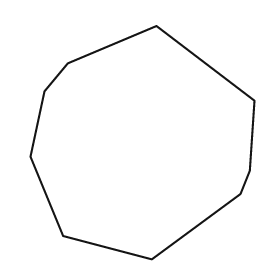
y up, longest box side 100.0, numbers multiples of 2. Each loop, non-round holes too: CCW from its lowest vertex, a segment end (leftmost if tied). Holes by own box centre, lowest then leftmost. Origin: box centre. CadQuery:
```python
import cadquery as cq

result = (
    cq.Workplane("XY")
    .moveTo(4.0, -50.0)
    .lineTo(42.0, -22.0)
    .lineTo(46.0, -12.0)
    .lineTo(48.0, 18.0)
    .lineTo(6.0, 50.0)
    .lineTo(-32.0, 34.0)
    .lineTo(-42.0, 22.0)
    .lineTo(-48.0, -6.0)
    .lineTo(-34.0, -40.0)
    .close()
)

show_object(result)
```